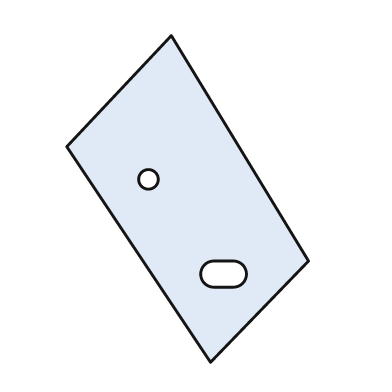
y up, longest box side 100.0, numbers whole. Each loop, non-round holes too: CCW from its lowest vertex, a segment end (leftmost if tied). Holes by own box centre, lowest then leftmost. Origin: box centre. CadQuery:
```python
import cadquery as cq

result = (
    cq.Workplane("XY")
    .moveTo(7.0, -50.0)
    .lineTo(37.0, -19.0)
    .lineTo(-5.0, 50.0)
    .lineTo(-37.0, 16.0)
    .close()
    .moveTo(8.0, -27.0)
    .lineTo(14.0, -27.0)
    .threePointArc((18.0, -23.0), (14.0, -19.0))
    .lineTo(8.0, -19.0)
    .threePointArc((4.0, -23.0), (8.0, -27.0))
    .close()
    .moveTo(-12.0, 6.0)
    .circle(3.0)
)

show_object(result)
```